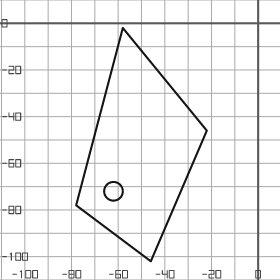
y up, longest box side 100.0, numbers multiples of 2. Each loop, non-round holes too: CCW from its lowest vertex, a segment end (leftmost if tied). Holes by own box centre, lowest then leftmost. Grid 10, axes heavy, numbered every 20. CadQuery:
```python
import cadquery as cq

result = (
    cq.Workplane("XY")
    .moveTo(-46.0, -102.0)
    .lineTo(-22.0, -46.0)
    .lineTo(-58.0, -2.0)
    .lineTo(-78.0, -78.0)
    .close()
    .moveTo(-62.0, -72.0)
    .circle(4.0)
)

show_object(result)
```